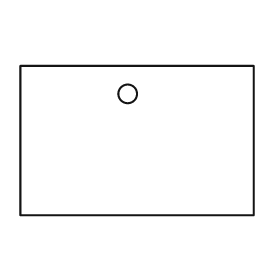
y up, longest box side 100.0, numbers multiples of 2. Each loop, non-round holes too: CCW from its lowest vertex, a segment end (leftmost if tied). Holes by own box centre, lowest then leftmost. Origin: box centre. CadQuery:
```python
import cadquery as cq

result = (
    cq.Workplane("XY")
    .moveTo(-50.0, -32.0)
    .lineTo(50.0, -32.0)
    .lineTo(50.0, 32.0)
    .lineTo(-50.0, 32.0)
    .close()
    .moveTo(-4.0, 20.0)
    .circle(4.0)
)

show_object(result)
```